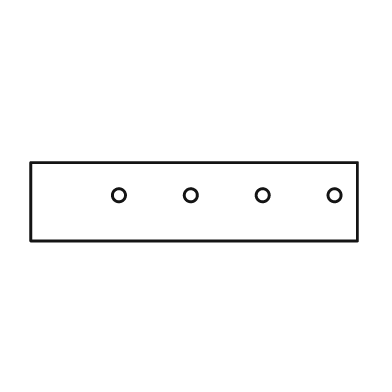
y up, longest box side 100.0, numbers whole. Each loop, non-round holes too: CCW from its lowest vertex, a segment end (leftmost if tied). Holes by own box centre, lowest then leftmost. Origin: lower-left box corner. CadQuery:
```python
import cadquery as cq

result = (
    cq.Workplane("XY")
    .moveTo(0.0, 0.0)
    .lineTo(100.0, 0.0)
    .lineTo(100.0, 24.0)
    .lineTo(0.0, 24.0)
    .close()
    .moveTo(27.0, 14.0)
    .circle(2.0)
    .moveTo(49.0, 14.0)
    .circle(2.0)
    .moveTo(71.0, 14.0)
    .circle(2.0)
    .moveTo(93.0, 14.0)
    .circle(2.0)
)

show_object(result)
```